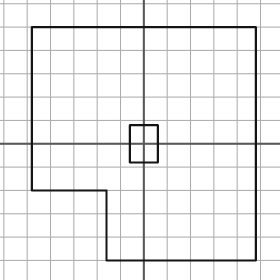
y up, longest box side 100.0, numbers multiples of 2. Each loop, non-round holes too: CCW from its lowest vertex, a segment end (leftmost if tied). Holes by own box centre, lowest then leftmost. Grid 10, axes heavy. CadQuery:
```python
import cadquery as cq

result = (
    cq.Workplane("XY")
    .moveTo(-16.0, -50.0)
    .lineTo(48.0, -50.0)
    .lineTo(48.0, 50.0)
    .lineTo(-48.0, 50.0)
    .lineTo(-48.0, -20.0)
    .lineTo(-16.0, -20.0)
    .close()
    .moveTo(-6.0, -8.0)
    .lineTo(6.0, -8.0)
    .lineTo(6.0, 8.0)
    .lineTo(-6.0, 8.0)
    .close()
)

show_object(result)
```